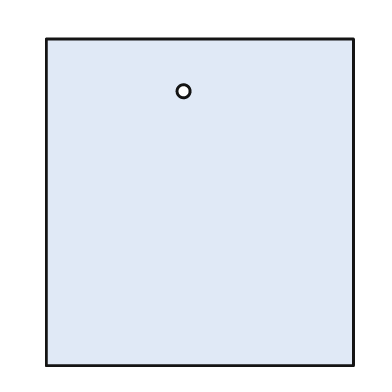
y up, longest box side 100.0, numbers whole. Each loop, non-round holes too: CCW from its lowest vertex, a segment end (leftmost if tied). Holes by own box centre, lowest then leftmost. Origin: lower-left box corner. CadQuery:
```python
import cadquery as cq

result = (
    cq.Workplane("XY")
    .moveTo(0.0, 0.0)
    .lineTo(94.0, 0.0)
    .lineTo(94.0, 100.0)
    .lineTo(0.0, 100.0)
    .close()
    .moveTo(42.0, 84.0)
    .circle(2.0)
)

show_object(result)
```